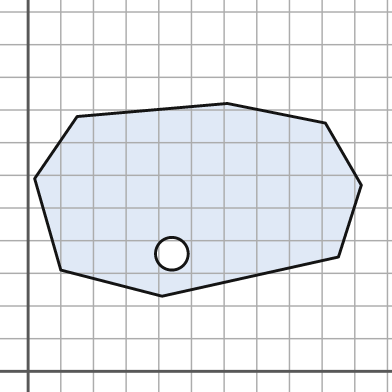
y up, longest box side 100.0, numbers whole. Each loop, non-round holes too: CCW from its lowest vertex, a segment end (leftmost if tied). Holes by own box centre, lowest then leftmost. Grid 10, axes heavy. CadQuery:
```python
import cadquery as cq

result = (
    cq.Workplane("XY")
    .moveTo(41.0, 23.0)
    .lineTo(95.0, 35.0)
    .lineTo(102.0, 57.0)
    .lineTo(91.0, 76.0)
    .lineTo(61.0, 82.0)
    .lineTo(15.0, 78.0)
    .lineTo(2.0, 59.0)
    .lineTo(10.0, 31.0)
    .close()
    .moveTo(44.0, 36.0)
    .circle(5.0)
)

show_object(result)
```